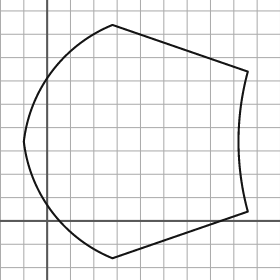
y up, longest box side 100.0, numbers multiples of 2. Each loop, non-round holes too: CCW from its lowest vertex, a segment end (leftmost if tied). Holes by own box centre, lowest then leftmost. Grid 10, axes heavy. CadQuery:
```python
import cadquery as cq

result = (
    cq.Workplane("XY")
    .moveTo(28.0, -16.0)
    .lineTo(86.0, 4.0)
    .threePointArc((82.0, 34.0), (86.0, 64.0))
    .lineTo(28.0, 84.0)
    .threePointArc((2.0, 64.0), (-10.0, 34.0))
    .threePointArc((2.0, 4.0), (28.0, -16.0))
    .close()
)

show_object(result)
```